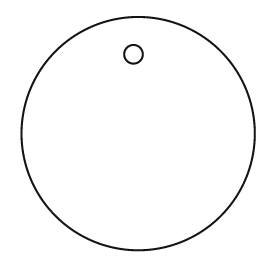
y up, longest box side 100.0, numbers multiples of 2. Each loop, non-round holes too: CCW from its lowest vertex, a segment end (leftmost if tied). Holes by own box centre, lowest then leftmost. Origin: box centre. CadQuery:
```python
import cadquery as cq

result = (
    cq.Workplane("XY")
    .moveTo(0.0, 0.0)
    .circle(50.0)
    .moveTo(-2.0, 34.0)
    .circle(4.0)
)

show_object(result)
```